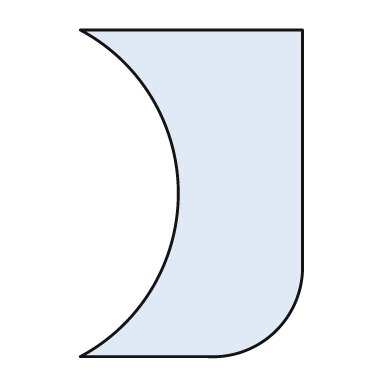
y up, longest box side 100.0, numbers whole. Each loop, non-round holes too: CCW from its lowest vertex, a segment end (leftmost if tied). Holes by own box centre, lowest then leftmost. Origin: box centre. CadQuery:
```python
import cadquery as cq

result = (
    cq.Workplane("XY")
    .moveTo(-34.0, -50.0)
    .lineTo(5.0, -50.0)
    .threePointArc((26.0, -42.0), (34.0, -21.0))
    .lineTo(34.0, 50.0)
    .lineTo(-34.0, 50.0)
    .threePointArc((-4.0, 0.0), (-34.0, -50.0))
    .close()
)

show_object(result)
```